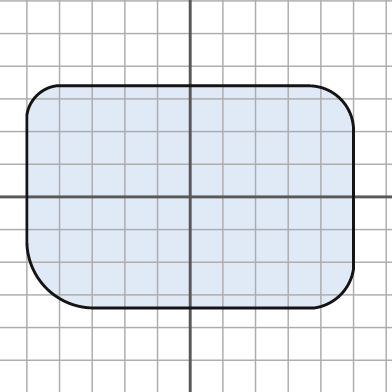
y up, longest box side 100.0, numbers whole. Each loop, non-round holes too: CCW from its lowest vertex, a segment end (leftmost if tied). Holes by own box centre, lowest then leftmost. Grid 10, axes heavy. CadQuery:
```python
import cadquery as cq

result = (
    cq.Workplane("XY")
    .moveTo(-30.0, -34.0)
    .lineTo(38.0, -34.0)
    .threePointArc((46.0, -30.0), (50.0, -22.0))
    .lineTo(50.0, 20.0)
    .threePointArc((46.0, 30.0), (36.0, 34.0))
    .lineTo(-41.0, 34.0)
    .threePointArc((-47.0, 31.0), (-50.0, 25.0))
    .lineTo(-50.0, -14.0)
    .threePointArc((-44.0, -28.0), (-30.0, -34.0))
    .close()
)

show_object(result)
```